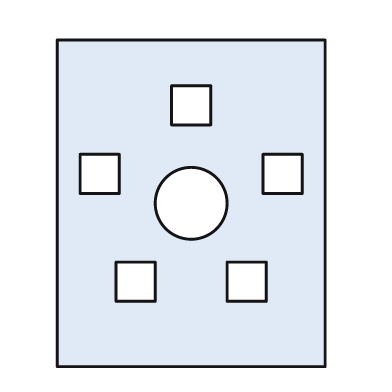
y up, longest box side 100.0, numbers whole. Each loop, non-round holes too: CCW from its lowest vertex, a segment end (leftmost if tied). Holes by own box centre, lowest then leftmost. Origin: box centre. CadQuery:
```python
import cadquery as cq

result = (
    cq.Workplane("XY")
    .moveTo(-41.0, -50.0)
    .lineTo(41.0, -50.0)
    .lineTo(41.0, 50.0)
    .lineTo(-41.0, 50.0)
    .close()
    .moveTo(-23.0, -30.0)
    .lineTo(-11.0, -30.0)
    .lineTo(-11.0, -18.0)
    .lineTo(-23.0, -18.0)
    .close()
    .moveTo(11.0, -30.0)
    .lineTo(23.0, -30.0)
    .lineTo(23.0, -18.0)
    .lineTo(11.0, -18.0)
    .close()
    .moveTo(0.0, 0.0)
    .circle(11.0)
    .moveTo(-34.0, 3.0)
    .lineTo(-22.0, 3.0)
    .lineTo(-22.0, 15.0)
    .lineTo(-34.0, 15.0)
    .close()
    .moveTo(22.0, 3.0)
    .lineTo(34.0, 3.0)
    .lineTo(34.0, 15.0)
    .lineTo(22.0, 15.0)
    .close()
    .moveTo(-6.0, 24.0)
    .lineTo(6.0, 24.0)
    .lineTo(6.0, 36.0)
    .lineTo(-6.0, 36.0)
    .close()
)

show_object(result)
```